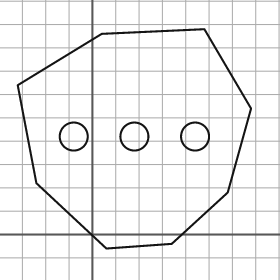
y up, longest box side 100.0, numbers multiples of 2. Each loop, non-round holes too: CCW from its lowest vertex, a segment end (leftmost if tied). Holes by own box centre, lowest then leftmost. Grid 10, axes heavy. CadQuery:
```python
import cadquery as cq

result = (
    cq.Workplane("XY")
    .moveTo(6.0, -6.0)
    .lineTo(34.0, -4.0)
    .lineTo(58.0, 18.0)
    .lineTo(68.0, 54.0)
    .lineTo(48.0, 88.0)
    .lineTo(4.0, 86.0)
    .lineTo(-32.0, 64.0)
    .lineTo(-24.0, 22.0)
    .close()
    .moveTo(-8.0, 42.0)
    .circle(6.0)
    .moveTo(18.0, 42.0)
    .circle(6.0)
    .moveTo(44.0, 42.0)
    .circle(6.0)
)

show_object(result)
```